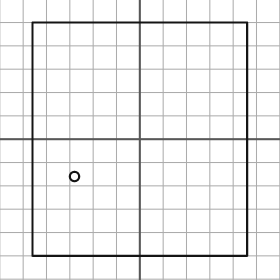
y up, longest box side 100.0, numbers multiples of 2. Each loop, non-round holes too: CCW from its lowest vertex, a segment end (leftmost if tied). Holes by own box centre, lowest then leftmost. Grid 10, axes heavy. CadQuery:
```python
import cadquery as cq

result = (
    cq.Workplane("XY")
    .moveTo(-46.0, -50.0)
    .lineTo(46.0, -50.0)
    .lineTo(46.0, 50.0)
    .lineTo(-46.0, 50.0)
    .close()
    .moveTo(-28.0, -16.0)
    .circle(2.0)
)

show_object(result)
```